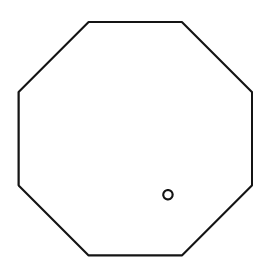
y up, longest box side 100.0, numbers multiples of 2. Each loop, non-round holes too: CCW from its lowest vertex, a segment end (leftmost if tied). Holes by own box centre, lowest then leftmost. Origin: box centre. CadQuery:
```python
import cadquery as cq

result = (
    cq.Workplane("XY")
    .moveTo(-20.0, -50.0)
    .lineTo(20.0, -50.0)
    .lineTo(50.0, -20.0)
    .lineTo(50.0, 20.0)
    .lineTo(20.0, 50.0)
    .lineTo(-20.0, 50.0)
    .lineTo(-50.0, 20.0)
    .lineTo(-50.0, -20.0)
    .close()
    .moveTo(14.0, -24.0)
    .circle(2.0)
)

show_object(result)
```